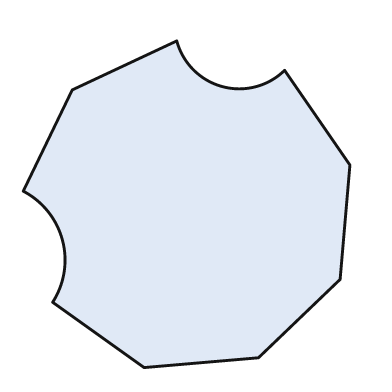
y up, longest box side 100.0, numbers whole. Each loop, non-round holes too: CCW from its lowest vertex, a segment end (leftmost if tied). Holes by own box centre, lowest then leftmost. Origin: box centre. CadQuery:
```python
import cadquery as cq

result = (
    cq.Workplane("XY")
    .moveTo(-13.0, -50.0)
    .lineTo(22.0, -47.0)
    .lineTo(47.0, -23.0)
    .lineTo(50.0, 12.0)
    .lineTo(30.0, 41.0)
    .threePointArc((11.0, 36.0), (-3.0, 50.0))
    .lineTo(-35.0, 35.0)
    .lineTo(-50.0, 4.0)
    .threePointArc((-38.0, -11.0), (-41.0, -30.0))
    .close()
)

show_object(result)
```